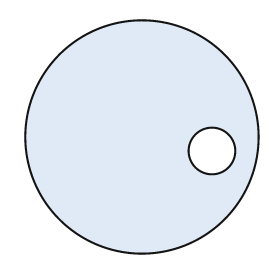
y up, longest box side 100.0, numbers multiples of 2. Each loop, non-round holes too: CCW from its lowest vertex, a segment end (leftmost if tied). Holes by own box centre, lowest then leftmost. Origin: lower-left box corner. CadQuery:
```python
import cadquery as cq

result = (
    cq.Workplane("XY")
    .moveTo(50.0, 50.0)
    .circle(50.0)
    .moveTo(80.0, 44.0)
    .circle(10.0)
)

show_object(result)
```